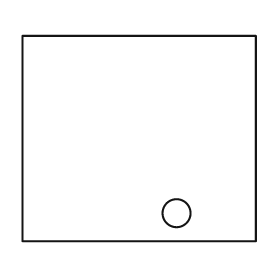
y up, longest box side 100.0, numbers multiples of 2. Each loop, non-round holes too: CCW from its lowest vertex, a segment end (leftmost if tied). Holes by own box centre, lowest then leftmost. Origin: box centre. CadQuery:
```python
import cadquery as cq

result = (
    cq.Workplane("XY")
    .moveTo(-50.0, -44.0)
    .lineTo(50.0, -44.0)
    .lineTo(50.0, 44.0)
    .lineTo(-50.0, 44.0)
    .close()
    .moveTo(16.0, -32.0)
    .circle(6.0)
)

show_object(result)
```